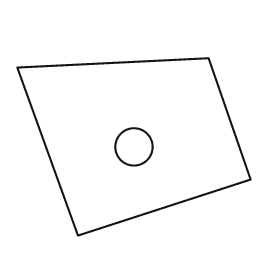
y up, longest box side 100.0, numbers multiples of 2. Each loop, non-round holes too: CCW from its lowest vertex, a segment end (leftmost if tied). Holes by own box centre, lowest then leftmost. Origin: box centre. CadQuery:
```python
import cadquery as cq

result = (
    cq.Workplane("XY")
    .moveTo(-24.0, -38.0)
    .lineTo(50.0, -14.0)
    .lineTo(32.0, 38.0)
    .lineTo(-50.0, 34.0)
    .close()
    .moveTo(0.0, 0.0)
    .circle(8.0)
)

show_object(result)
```